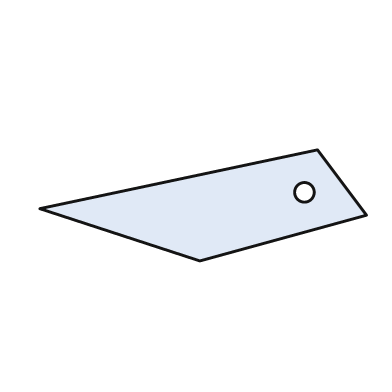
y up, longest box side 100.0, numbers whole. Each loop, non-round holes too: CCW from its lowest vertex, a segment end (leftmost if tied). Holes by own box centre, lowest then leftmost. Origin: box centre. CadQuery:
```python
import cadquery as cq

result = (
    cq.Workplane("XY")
    .moveTo(-1.0, -17.0)
    .lineTo(50.0, -3.0)
    .lineTo(35.0, 17.0)
    .lineTo(-50.0, -1.0)
    .close()
    .moveTo(31.0, 4.0)
    .circle(3.0)
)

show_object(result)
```